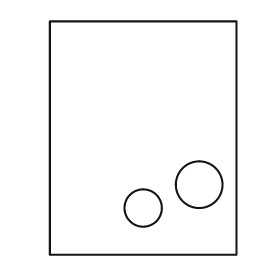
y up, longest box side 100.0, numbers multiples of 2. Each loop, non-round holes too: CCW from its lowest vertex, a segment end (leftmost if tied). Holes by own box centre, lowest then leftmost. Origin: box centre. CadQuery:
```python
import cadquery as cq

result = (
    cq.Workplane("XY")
    .moveTo(-40.0, -50.0)
    .lineTo(40.0, -50.0)
    .lineTo(40.0, 50.0)
    .lineTo(-40.0, 50.0)
    .close()
    .moveTo(0.0, -30.0)
    .circle(8.0)
    .moveTo(24.0, -20.0)
    .circle(10.0)
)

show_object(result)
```